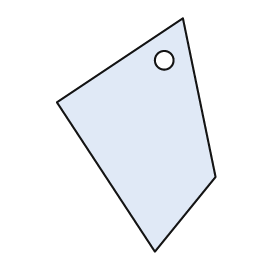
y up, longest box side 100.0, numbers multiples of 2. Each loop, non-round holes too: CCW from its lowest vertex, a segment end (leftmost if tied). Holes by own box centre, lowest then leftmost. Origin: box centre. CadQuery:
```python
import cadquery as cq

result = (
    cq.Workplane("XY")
    .moveTo(8.0, -50.0)
    .lineTo(34.0, -18.0)
    .lineTo(20.0, 50.0)
    .lineTo(-34.0, 14.0)
    .close()
    .moveTo(12.0, 32.0)
    .circle(4.0)
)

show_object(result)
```